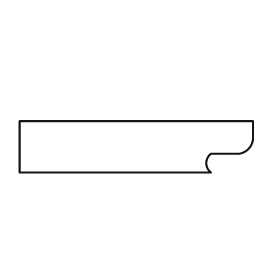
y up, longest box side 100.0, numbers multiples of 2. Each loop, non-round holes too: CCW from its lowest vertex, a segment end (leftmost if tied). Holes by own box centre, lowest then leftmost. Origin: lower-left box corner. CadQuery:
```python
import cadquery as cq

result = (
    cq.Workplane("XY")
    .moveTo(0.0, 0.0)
    .lineTo(82.0, 0.0)
    .threePointArc((80.0, 4.0), (82.0, 8.0))
    .lineTo(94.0, 8.0)
    .threePointArc((98.0, 10.0), (100.0, 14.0))
    .lineTo(100.0, 22.0)
    .lineTo(0.0, 22.0)
    .close()
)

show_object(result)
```